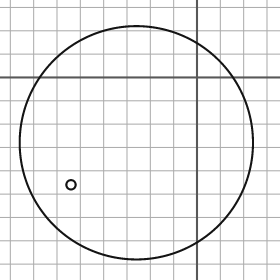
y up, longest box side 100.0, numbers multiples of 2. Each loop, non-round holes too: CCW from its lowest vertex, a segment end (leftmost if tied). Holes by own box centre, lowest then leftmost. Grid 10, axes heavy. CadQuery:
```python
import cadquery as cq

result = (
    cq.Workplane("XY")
    .moveTo(-26.0, -28.0)
    .circle(50.0)
    .moveTo(-54.0, -46.0)
    .circle(2.0)
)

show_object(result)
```